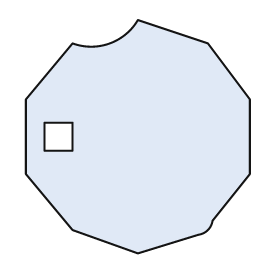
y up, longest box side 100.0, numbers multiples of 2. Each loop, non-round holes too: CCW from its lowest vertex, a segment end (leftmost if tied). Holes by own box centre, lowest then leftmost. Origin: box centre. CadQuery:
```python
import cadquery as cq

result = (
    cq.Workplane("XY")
    .moveTo(0.0, -50.0)
    .lineTo(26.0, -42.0)
    .threePointArc((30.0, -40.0), (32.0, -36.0))
    .lineTo(48.0, -16.0)
    .lineTo(48.0, 16.0)
    .lineTo(30.0, 40.0)
    .lineTo(0.0, 50.0)
    .threePointArc((-12.0, 40.0), (-28.0, 40.0))
    .lineTo(-48.0, 16.0)
    .lineTo(-48.0, -16.0)
    .lineTo(-28.0, -40.0)
    .close()
    .moveTo(-40.0, -6.0)
    .lineTo(-28.0, -6.0)
    .lineTo(-28.0, 6.0)
    .lineTo(-40.0, 6.0)
    .close()
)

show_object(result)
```